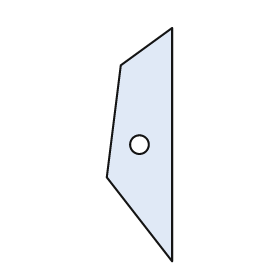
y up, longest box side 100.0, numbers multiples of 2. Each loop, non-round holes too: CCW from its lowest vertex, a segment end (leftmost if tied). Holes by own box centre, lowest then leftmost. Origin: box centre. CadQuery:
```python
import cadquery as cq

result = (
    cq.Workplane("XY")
    .moveTo(14.0, -50.0)
    .lineTo(14.0, 50.0)
    .lineTo(-8.0, 34.0)
    .lineTo(-14.0, -14.0)
    .close()
    .moveTo(0.0, 0.0)
    .circle(4.0)
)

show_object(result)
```